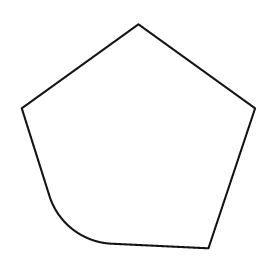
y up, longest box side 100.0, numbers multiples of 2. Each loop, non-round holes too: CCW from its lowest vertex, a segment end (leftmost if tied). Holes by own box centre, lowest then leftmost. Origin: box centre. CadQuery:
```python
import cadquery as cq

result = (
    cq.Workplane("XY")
    .moveTo(30.0, -48.0)
    .lineTo(50.0, 12.0)
    .lineTo(0.0, 48.0)
    .lineTo(-50.0, 12.0)
    .lineTo(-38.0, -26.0)
    .threePointArc((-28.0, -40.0), (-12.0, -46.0))
    .close()
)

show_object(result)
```